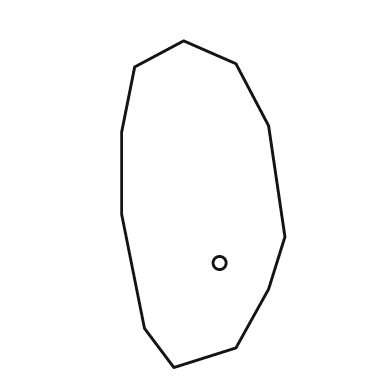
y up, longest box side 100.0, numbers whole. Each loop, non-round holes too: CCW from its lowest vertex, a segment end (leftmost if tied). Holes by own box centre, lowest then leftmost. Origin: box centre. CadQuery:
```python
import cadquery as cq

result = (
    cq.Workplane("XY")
    .moveTo(-9.0, -50.0)
    .lineTo(10.0, -44.0)
    .lineTo(20.0, -26.0)
    .lineTo(25.0, -10.0)
    .lineTo(20.0, 24.0)
    .lineTo(10.0, 43.0)
    .lineTo(-6.0, 50.0)
    .lineTo(-21.0, 42.0)
    .lineTo(-25.0, 22.0)
    .lineTo(-25.0, -3.0)
    .lineTo(-18.0, -38.0)
    .close()
    .moveTo(5.0, -18.0)
    .circle(2.0)
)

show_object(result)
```